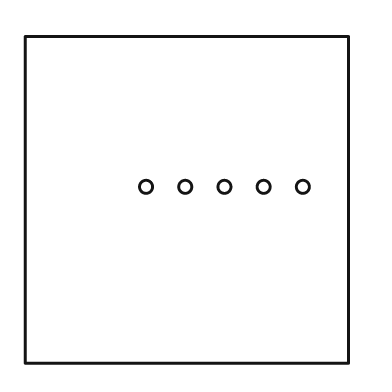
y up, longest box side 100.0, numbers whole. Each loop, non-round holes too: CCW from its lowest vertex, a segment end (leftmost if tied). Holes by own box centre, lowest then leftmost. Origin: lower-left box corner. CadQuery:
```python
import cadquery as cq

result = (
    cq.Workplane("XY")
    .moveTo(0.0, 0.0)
    .lineTo(99.0, 0.0)
    .lineTo(99.0, 100.0)
    .lineTo(0.0, 100.0)
    .close()
    .moveTo(37.0, 54.0)
    .circle(2.0)
    .moveTo(49.0, 54.0)
    .circle(2.0)
    .moveTo(61.0, 54.0)
    .circle(2.0)
    .moveTo(73.0, 54.0)
    .circle(2.0)
    .moveTo(85.0, 54.0)
    .circle(2.0)
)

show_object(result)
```